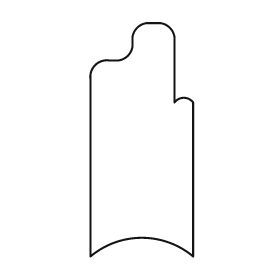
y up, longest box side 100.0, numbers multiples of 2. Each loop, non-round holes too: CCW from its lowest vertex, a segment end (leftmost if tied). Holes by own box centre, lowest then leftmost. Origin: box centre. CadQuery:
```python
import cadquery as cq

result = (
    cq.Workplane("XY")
    .moveTo(-22.0, -50.0)
    .threePointArc((0.0, -42.0), (22.0, -50.0))
    .lineTo(22.0, 16.0)
    .threePointArc((18.0, 18.0), (14.0, 16.0))
    .lineTo(14.0, 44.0)
    .threePointArc((12.0, 48.0), (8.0, 50.0))
    .lineTo(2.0, 50.0)
    .threePointArc((-2.0, 48.0), (-4.0, 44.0))
    .lineTo(-4.0, 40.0)
    .threePointArc((-6.0, 36.0), (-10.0, 34.0))
    .lineTo(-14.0, 34.0)
    .threePointArc((-20.0, 32.0), (-22.0, 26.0))
    .close()
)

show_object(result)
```